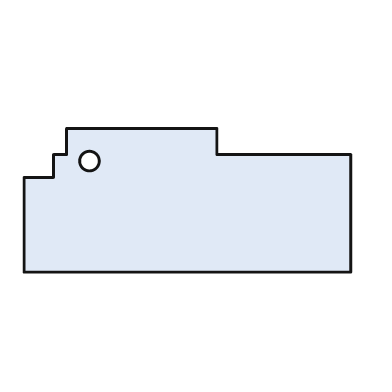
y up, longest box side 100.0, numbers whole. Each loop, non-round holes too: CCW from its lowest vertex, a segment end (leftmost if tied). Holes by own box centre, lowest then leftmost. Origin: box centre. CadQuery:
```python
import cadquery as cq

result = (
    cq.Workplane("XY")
    .moveTo(-50.0, -22.0)
    .lineTo(50.0, -22.0)
    .lineTo(50.0, 14.0)
    .lineTo(9.0, 14.0)
    .lineTo(9.0, 22.0)
    .lineTo(-37.0, 22.0)
    .lineTo(-37.0, 14.0)
    .lineTo(-41.0, 14.0)
    .lineTo(-41.0, 7.0)
    .lineTo(-50.0, 7.0)
    .close()
    .moveTo(-30.0, 12.0)
    .circle(3.0)
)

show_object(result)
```